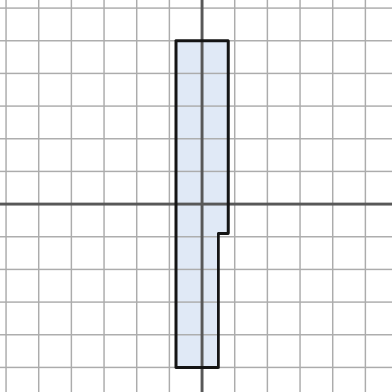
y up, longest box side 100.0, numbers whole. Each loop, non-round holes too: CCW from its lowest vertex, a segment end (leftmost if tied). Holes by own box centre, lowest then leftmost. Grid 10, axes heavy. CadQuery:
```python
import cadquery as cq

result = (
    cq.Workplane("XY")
    .moveTo(-8.0, -50.0)
    .lineTo(5.0, -50.0)
    .lineTo(5.0, -9.0)
    .lineTo(8.0, -9.0)
    .lineTo(8.0, 50.0)
    .lineTo(-8.0, 50.0)
    .close()
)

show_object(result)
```